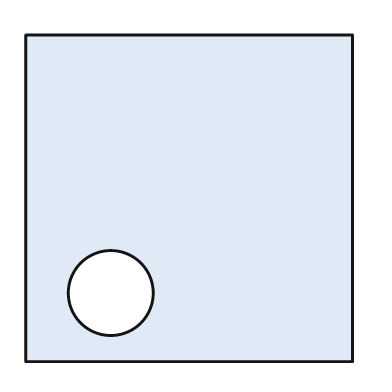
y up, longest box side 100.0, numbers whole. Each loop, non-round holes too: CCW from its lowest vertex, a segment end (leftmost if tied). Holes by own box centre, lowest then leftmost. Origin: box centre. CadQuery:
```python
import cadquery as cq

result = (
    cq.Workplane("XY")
    .moveTo(-50.0, -50.0)
    .lineTo(50.0, -50.0)
    .lineTo(50.0, 50.0)
    .lineTo(-50.0, 50.0)
    .close()
    .moveTo(-24.0, -29.0)
    .circle(13.0)
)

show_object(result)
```